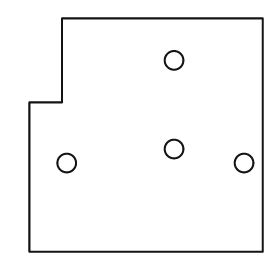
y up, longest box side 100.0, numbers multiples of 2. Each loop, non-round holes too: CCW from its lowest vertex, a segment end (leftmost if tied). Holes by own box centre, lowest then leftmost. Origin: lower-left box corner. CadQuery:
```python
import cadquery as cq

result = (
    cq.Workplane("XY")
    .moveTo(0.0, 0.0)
    .lineTo(100.0, 0.0)
    .lineTo(100.0, 100.0)
    .lineTo(14.0, 100.0)
    .lineTo(14.0, 64.0)
    .lineTo(0.0, 64.0)
    .close()
    .moveTo(16.0, 38.0)
    .circle(4.0)
    .moveTo(92.0, 38.0)
    .circle(4.0)
    .moveTo(62.0, 44.0)
    .circle(4.0)
    .moveTo(62.0, 82.0)
    .circle(4.0)
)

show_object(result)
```